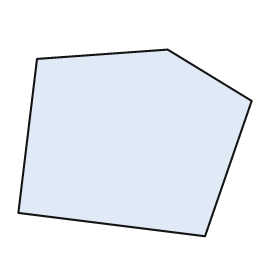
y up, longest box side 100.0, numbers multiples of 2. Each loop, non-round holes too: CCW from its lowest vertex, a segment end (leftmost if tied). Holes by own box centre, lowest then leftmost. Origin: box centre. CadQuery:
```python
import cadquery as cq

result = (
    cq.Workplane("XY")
    .moveTo(30.0, -40.0)
    .lineTo(50.0, 18.0)
    .lineTo(14.0, 40.0)
    .lineTo(-42.0, 36.0)
    .lineTo(-50.0, -30.0)
    .close()
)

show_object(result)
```